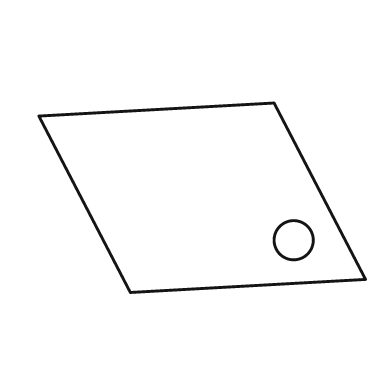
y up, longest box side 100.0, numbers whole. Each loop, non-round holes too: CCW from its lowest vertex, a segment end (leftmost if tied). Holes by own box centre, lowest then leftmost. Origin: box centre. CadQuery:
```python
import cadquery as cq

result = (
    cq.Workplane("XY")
    .moveTo(-22.0, -29.0)
    .lineTo(50.0, -25.0)
    .lineTo(22.0, 29.0)
    .lineTo(-50.0, 25.0)
    .close()
    .moveTo(28.0, -13.0)
    .circle(6.0)
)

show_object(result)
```